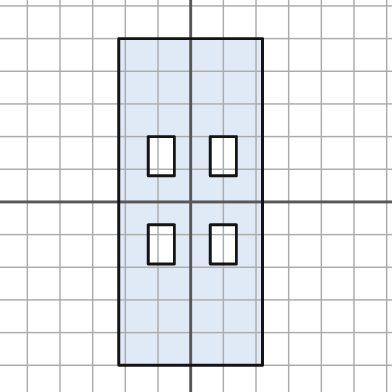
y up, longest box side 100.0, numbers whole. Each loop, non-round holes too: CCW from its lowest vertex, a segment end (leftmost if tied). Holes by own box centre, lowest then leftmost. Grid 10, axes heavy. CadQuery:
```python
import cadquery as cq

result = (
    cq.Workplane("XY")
    .moveTo(-22.0, -50.0)
    .lineTo(22.0, -50.0)
    .lineTo(22.0, 50.0)
    .lineTo(-22.0, 50.0)
    .close()
    .moveTo(-13.0, -19.0)
    .lineTo(-5.0, -19.0)
    .lineTo(-5.0, -7.0)
    .lineTo(-13.0, -7.0)
    .close()
    .moveTo(6.0, -19.0)
    .lineTo(14.0, -19.0)
    .lineTo(14.0, -7.0)
    .lineTo(6.0, -7.0)
    .close()
    .moveTo(-13.0, 8.0)
    .lineTo(-5.0, 8.0)
    .lineTo(-5.0, 20.0)
    .lineTo(-13.0, 20.0)
    .close()
    .moveTo(6.0, 8.0)
    .lineTo(14.0, 8.0)
    .lineTo(14.0, 20.0)
    .lineTo(6.0, 20.0)
    .close()
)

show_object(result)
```